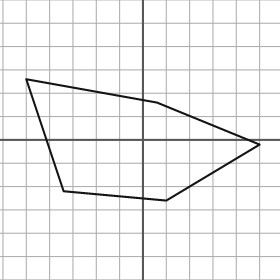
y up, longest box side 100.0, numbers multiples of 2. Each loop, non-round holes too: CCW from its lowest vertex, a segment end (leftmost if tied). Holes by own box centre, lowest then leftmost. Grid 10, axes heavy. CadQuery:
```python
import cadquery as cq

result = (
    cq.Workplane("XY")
    .moveTo(10.0, -26.0)
    .lineTo(50.0, -2.0)
    .lineTo(6.0, 16.0)
    .lineTo(-50.0, 26.0)
    .lineTo(-34.0, -22.0)
    .close()
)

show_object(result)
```